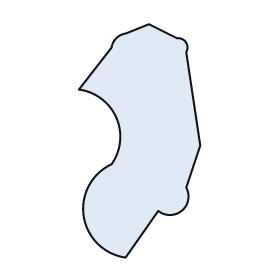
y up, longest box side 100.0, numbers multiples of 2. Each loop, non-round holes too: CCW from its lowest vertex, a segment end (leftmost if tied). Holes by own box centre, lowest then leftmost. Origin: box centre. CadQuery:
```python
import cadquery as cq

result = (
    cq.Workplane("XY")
    .moveTo(-6.0, -50.0)
    .lineTo(8.0, -30.0)
    .threePointArc((18.0, -30.0), (20.0, -20.0))
    .lineTo(26.0, -2.0)
    .lineTo(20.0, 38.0)
    .threePointArc((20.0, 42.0), (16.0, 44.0))
    .lineTo(4.0, 50.0)
    .lineTo(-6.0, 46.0)
    .threePointArc((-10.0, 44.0), (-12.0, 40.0))
    .lineTo(-26.0, 22.0)
    .threePointArc((-10.0, 10.0), (-12.0, -10.0))
    .threePointArc((-24.0, -32.0), (-6.0, -50.0))
    .close()
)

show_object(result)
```